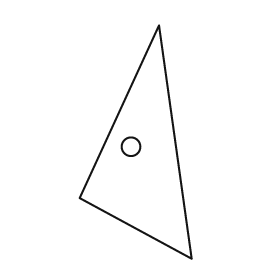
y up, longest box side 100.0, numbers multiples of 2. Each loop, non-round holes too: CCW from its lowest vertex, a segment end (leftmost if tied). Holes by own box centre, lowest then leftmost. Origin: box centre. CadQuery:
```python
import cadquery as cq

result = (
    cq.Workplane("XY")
    .moveTo(24.0, -50.0)
    .lineTo(10.0, 50.0)
    .lineTo(-24.0, -24.0)
    .close()
    .moveTo(-2.0, -2.0)
    .circle(4.0)
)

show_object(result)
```